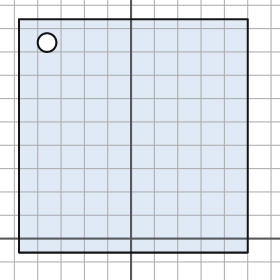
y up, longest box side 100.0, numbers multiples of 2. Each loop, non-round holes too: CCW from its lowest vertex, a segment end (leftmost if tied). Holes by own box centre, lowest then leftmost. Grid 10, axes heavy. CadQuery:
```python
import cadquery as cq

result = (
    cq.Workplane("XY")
    .moveTo(-48.0, -6.0)
    .lineTo(50.0, -6.0)
    .lineTo(50.0, 94.0)
    .lineTo(-48.0, 94.0)
    .close()
    .moveTo(-36.0, 84.0)
    .circle(4.0)
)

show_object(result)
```